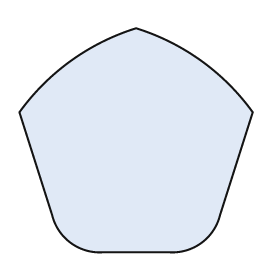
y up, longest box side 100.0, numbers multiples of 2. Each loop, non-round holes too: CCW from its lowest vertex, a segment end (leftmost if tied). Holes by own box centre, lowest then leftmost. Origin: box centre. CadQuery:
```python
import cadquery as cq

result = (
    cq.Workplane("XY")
    .moveTo(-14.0, -48.0)
    .lineTo(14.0, -48.0)
    .threePointArc((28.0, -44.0), (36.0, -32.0))
    .lineTo(50.0, 12.0)
    .threePointArc((28.0, 34.0), (0.0, 48.0))
    .threePointArc((-28.0, 34.0), (-50.0, 12.0))
    .lineTo(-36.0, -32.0)
    .threePointArc((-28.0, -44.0), (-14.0, -48.0))
    .close()
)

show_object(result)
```